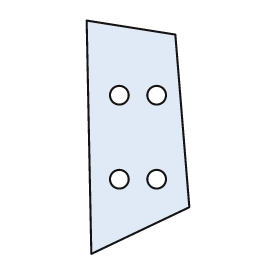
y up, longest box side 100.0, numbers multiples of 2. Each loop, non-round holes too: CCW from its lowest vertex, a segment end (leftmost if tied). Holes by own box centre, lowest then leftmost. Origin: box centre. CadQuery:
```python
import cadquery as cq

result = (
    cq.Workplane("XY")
    .moveTo(-20.0, -50.0)
    .lineTo(22.0, -30.0)
    .lineTo(16.0, 44.0)
    .lineTo(-22.0, 50.0)
    .close()
    .moveTo(-8.0, -18.0)
    .circle(4.0)
    .moveTo(8.0, -18.0)
    .circle(4.0)
    .moveTo(-8.0, 18.0)
    .circle(4.0)
    .moveTo(8.0, 18.0)
    .circle(4.0)
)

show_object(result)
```